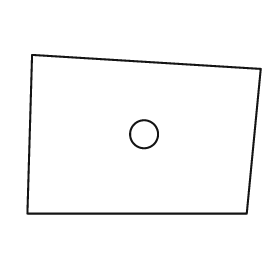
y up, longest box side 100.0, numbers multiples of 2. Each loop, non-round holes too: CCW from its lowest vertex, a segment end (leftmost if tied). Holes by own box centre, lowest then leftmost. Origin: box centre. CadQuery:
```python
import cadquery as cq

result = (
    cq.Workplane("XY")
    .moveTo(-50.0, -34.0)
    .lineTo(44.0, -34.0)
    .lineTo(50.0, 28.0)
    .lineTo(-48.0, 34.0)
    .close()
    .moveTo(0.0, 0.0)
    .circle(6.0)
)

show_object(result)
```